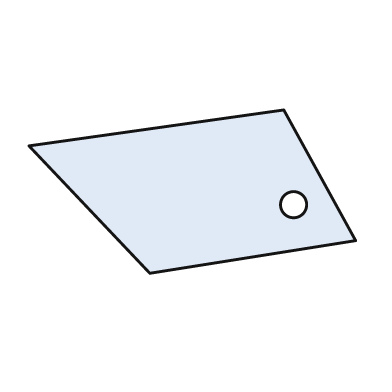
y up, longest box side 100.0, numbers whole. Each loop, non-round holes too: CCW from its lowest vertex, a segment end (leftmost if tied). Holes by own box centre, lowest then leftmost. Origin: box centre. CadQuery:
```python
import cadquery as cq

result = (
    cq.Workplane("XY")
    .moveTo(-13.0, -25.0)
    .lineTo(50.0, -15.0)
    .lineTo(28.0, 25.0)
    .lineTo(-50.0, 14.0)
    .close()
    .moveTo(31.0, -4.0)
    .circle(4.0)
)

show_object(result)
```